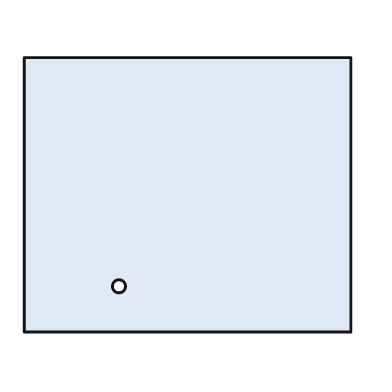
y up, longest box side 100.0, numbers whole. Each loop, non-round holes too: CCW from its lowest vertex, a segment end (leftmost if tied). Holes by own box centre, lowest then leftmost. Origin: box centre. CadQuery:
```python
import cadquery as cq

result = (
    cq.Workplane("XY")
    .moveTo(-50.0, -42.0)
    .lineTo(50.0, -42.0)
    .lineTo(50.0, 42.0)
    .lineTo(-50.0, 42.0)
    .close()
    .moveTo(-21.0, -28.0)
    .circle(2.0)
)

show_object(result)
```